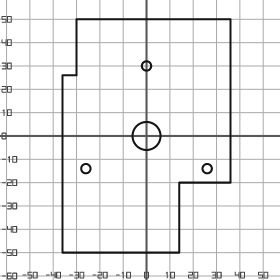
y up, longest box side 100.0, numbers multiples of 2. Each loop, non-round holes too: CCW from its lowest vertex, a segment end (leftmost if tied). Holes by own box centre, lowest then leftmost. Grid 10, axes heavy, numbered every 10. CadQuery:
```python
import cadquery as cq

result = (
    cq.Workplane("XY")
    .moveTo(-36.0, -50.0)
    .lineTo(14.0, -50.0)
    .lineTo(14.0, -20.0)
    .lineTo(36.0, -20.0)
    .lineTo(36.0, 50.0)
    .lineTo(-30.0, 50.0)
    .lineTo(-30.0, 26.0)
    .lineTo(-36.0, 26.0)
    .close()
    .moveTo(-26.0, -14.0)
    .circle(2.0)
    .moveTo(26.0, -14.0)
    .circle(2.0)
    .moveTo(0.0, 0.0)
    .circle(6.0)
    .moveTo(0.0, 30.0)
    .circle(2.0)
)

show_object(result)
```